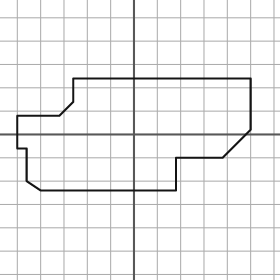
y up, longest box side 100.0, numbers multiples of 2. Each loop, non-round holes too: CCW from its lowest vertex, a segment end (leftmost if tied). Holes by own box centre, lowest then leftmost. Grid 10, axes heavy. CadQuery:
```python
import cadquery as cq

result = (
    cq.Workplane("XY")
    .moveTo(-40.0, -24.0)
    .lineTo(18.0, -24.0)
    .lineTo(18.0, -10.0)
    .lineTo(38.0, -10.0)
    .lineTo(50.0, 2.0)
    .lineTo(50.0, 24.0)
    .lineTo(-26.0, 24.0)
    .lineTo(-26.0, 14.0)
    .lineTo(-32.0, 8.0)
    .lineTo(-50.0, 8.0)
    .lineTo(-50.0, -6.0)
    .lineTo(-46.0, -6.0)
    .lineTo(-46.0, -20.0)
    .close()
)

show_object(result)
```